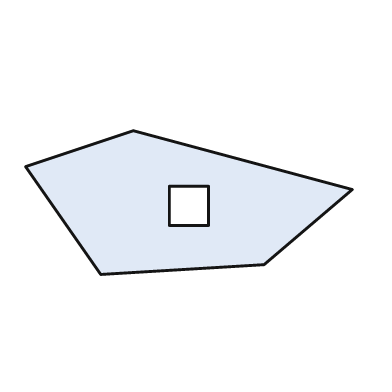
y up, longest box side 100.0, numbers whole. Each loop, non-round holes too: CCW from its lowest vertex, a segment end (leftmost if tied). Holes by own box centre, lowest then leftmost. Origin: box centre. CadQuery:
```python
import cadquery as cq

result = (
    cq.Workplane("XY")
    .moveTo(-27.0, -22.0)
    .lineTo(23.0, -19.0)
    .lineTo(50.0, 4.0)
    .lineTo(-17.0, 22.0)
    .lineTo(-50.0, 11.0)
    .close()
    .moveTo(-6.0, -7.0)
    .lineTo(6.0, -7.0)
    .lineTo(6.0, 5.0)
    .lineTo(-6.0, 5.0)
    .close()
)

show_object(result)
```